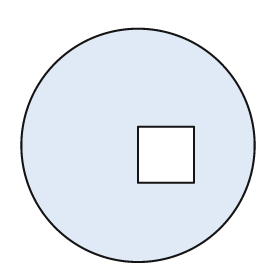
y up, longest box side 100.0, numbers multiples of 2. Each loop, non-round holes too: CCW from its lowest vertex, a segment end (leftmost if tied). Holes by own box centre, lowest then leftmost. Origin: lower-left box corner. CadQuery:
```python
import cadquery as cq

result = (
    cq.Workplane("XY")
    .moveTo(50.0, 50.0)
    .circle(50.0)
    .moveTo(50.0, 34.0)
    .lineTo(74.0, 34.0)
    .lineTo(74.0, 58.0)
    .lineTo(50.0, 58.0)
    .close()
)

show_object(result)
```